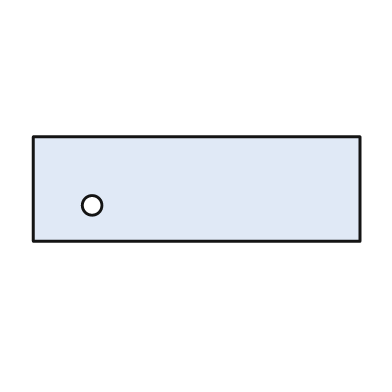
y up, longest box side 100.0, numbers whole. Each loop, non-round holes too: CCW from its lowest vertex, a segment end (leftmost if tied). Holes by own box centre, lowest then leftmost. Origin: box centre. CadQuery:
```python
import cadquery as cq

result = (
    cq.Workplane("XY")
    .moveTo(-50.0, -16.0)
    .lineTo(50.0, -16.0)
    .lineTo(50.0, 16.0)
    .lineTo(-50.0, 16.0)
    .close()
    .moveTo(-32.0, -5.0)
    .circle(3.0)
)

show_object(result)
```